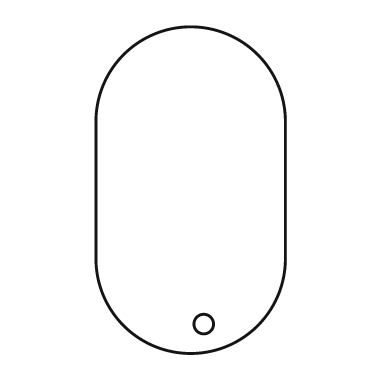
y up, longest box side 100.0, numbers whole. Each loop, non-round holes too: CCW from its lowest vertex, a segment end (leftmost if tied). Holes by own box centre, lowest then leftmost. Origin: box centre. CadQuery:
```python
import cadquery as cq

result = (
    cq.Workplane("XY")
    .moveTo(-29.0, -21.0)
    .threePointArc((0.0, -50.0), (29.0, -21.0))
    .lineTo(29.0, 21.0)
    .threePointArc((0.0, 50.0), (-29.0, 21.0))
    .close()
    .moveTo(4.0, -41.0)
    .circle(3.0)
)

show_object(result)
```